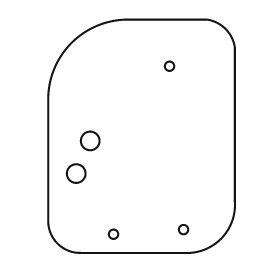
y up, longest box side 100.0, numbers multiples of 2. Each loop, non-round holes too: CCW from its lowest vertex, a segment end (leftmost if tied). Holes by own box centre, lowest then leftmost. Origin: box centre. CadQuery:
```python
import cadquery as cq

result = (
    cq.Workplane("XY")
    .moveTo(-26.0, -50.0)
    .lineTo(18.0, -50.0)
    .threePointArc((34.0, -44.0), (40.0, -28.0))
    .lineTo(40.0, 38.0)
    .threePointArc((36.0, 46.0), (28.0, 50.0))
    .lineTo(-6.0, 50.0)
    .threePointArc((-30.0, 40.0), (-40.0, 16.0))
    .lineTo(-40.0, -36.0)
    .threePointArc((-36.0, -46.0), (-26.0, -50.0))
    .close()
    .moveTo(-12.0, -42.0)
    .circle(2.0)
    .moveTo(18.0, -40.0)
    .circle(2.0)
    .moveTo(-28.0, -16.0)
    .circle(4.0)
    .moveTo(-22.0, -2.0)
    .circle(4.0)
    .moveTo(12.0, 30.0)
    .circle(2.0)
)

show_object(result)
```